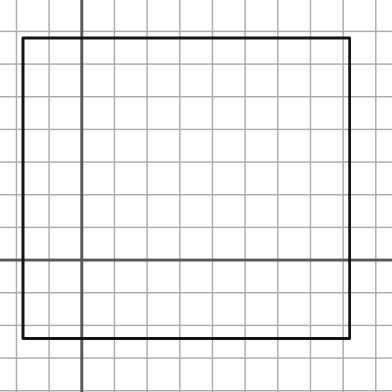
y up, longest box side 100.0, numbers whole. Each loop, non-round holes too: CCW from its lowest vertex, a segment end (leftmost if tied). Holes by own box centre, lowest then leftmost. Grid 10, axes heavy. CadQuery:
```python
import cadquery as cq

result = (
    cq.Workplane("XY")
    .moveTo(-18.0, -24.0)
    .lineTo(82.0, -24.0)
    .lineTo(82.0, 68.0)
    .lineTo(-18.0, 68.0)
    .close()
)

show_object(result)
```